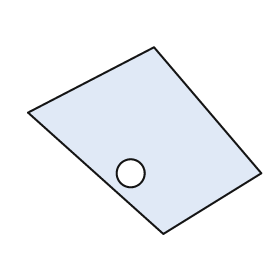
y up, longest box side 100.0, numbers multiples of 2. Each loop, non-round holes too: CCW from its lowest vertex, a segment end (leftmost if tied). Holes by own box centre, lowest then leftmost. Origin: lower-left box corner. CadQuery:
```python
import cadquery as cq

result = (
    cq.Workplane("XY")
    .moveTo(58.0, 0.0)
    .lineTo(100.0, 26.0)
    .lineTo(54.0, 80.0)
    .lineTo(0.0, 52.0)
    .close()
    .moveTo(44.0, 26.0)
    .circle(6.0)
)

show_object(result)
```